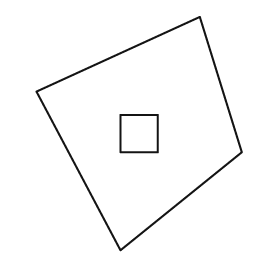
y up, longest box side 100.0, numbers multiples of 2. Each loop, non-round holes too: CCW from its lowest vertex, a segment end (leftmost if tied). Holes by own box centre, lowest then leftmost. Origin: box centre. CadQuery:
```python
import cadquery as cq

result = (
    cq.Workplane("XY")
    .moveTo(-8.0, -50.0)
    .lineTo(44.0, -8.0)
    .lineTo(26.0, 50.0)
    .lineTo(-44.0, 18.0)
    .close()
    .moveTo(-8.0, -8.0)
    .lineTo(8.0, -8.0)
    .lineTo(8.0, 8.0)
    .lineTo(-8.0, 8.0)
    .close()
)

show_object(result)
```